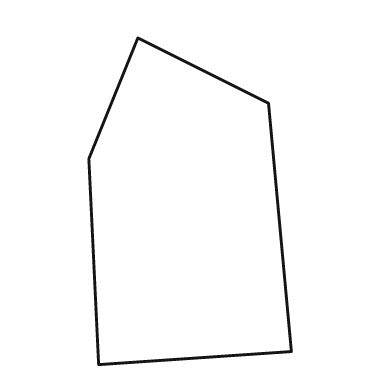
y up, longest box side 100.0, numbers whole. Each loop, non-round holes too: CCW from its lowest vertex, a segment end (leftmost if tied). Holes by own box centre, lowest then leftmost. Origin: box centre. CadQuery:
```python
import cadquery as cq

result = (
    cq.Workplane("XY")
    .moveTo(-28.0, -50.0)
    .lineTo(31.0, -46.0)
    .lineTo(24.0, 30.0)
    .lineTo(-16.0, 50.0)
    .lineTo(-31.0, 13.0)
    .close()
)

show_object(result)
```